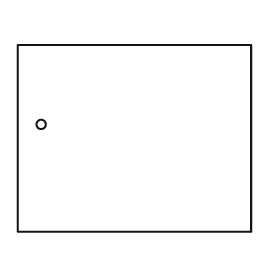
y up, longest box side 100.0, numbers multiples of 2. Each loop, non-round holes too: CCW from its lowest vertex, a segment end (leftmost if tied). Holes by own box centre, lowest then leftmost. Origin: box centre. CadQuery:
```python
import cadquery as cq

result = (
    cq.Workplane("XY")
    .moveTo(-50.0, -40.0)
    .lineTo(50.0, -40.0)
    .lineTo(50.0, 40.0)
    .lineTo(-50.0, 40.0)
    .close()
    .moveTo(-40.0, 6.0)
    .circle(2.0)
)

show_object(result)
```